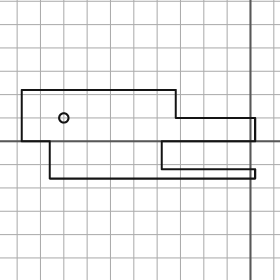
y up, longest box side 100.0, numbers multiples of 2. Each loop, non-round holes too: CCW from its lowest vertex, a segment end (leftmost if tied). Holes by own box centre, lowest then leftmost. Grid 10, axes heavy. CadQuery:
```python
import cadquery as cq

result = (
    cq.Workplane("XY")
    .moveTo(-86.0, -16.0)
    .lineTo(2.0, -16.0)
    .lineTo(2.0, -12.0)
    .lineTo(-38.0, -12.0)
    .lineTo(-38.0, 0.0)
    .lineTo(2.0, 0.0)
    .lineTo(2.0, 10.0)
    .lineTo(-32.0, 10.0)
    .lineTo(-32.0, 22.0)
    .lineTo(-98.0, 22.0)
    .lineTo(-98.0, 0.0)
    .lineTo(-86.0, 0.0)
    .close()
    .moveTo(-80.0, 10.0)
    .circle(2.0)
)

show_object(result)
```